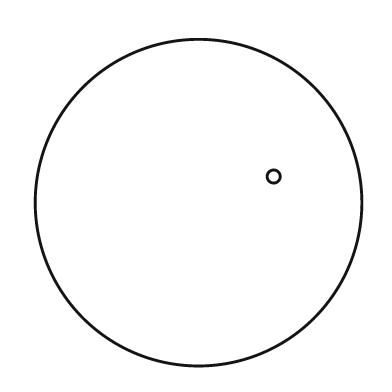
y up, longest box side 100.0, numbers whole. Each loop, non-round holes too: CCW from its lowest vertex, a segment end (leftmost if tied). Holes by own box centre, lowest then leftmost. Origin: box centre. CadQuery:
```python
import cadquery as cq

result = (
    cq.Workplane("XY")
    .moveTo(0.0, 0.0)
    .circle(50.0)
    .moveTo(23.0, 8.0)
    .circle(2.0)
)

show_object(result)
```